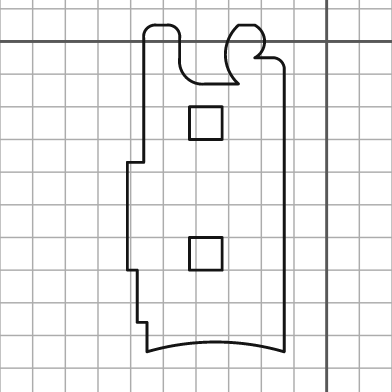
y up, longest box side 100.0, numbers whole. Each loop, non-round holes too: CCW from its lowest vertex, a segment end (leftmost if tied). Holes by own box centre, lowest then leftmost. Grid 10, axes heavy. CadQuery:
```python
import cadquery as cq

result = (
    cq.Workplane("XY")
    .moveTo(-55.0, -95.0)
    .threePointArc((-34.0, -92.0), (-13.0, -95.0))
    .lineTo(-13.0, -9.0)
    .threePointArc((-14.0, -6.0), (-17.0, -5.0))
    .lineTo(-22.0, -5.0)
    .threePointArc((-19.0, 0.0), (-22.0, 5.0))
    .lineTo(-27.0, 5.0)
    .threePointArc((-31.0, -4.0), (-27.0, -13.0))
    .lineTo(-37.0, -13.0)
    .threePointArc((-43.0, -11.0), (-45.0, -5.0))
    .lineTo(-45.0, 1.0)
    .threePointArc((-46.0, 4.0), (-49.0, 5.0))
    .lineTo(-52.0, 5.0)
    .threePointArc((-55.0, 4.0), (-56.0, 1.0))
    .lineTo(-56.0, -37.0)
    .lineTo(-61.0, -37.0)
    .lineTo(-61.0, -70.0)
    .lineTo(-58.0, -70.0)
    .lineTo(-58.0, -86.0)
    .lineTo(-55.0, -86.0)
    .close()
    .moveTo(-42.0, -70.0)
    .lineTo(-32.0, -70.0)
    .lineTo(-32.0, -60.0)
    .lineTo(-42.0, -60.0)
    .close()
    .moveTo(-42.0, -30.0)
    .lineTo(-32.0, -30.0)
    .lineTo(-32.0, -20.0)
    .lineTo(-42.0, -20.0)
    .close()
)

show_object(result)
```